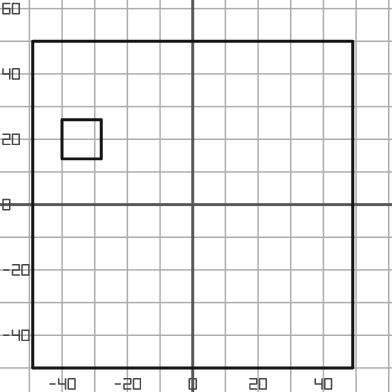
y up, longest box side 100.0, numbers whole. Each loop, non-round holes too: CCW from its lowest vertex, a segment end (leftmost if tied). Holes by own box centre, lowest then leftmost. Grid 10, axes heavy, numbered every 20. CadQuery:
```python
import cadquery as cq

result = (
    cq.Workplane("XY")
    .moveTo(-49.0, -50.0)
    .lineTo(49.0, -50.0)
    .lineTo(49.0, 50.0)
    .lineTo(-49.0, 50.0)
    .close()
    .moveTo(-40.0, 14.0)
    .lineTo(-28.0, 14.0)
    .lineTo(-28.0, 26.0)
    .lineTo(-40.0, 26.0)
    .close()
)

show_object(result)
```